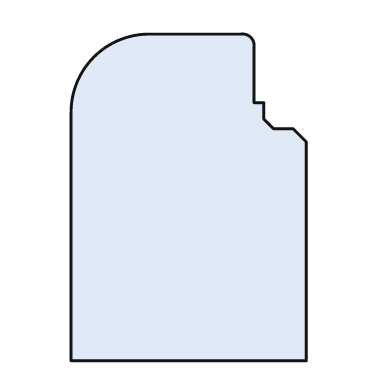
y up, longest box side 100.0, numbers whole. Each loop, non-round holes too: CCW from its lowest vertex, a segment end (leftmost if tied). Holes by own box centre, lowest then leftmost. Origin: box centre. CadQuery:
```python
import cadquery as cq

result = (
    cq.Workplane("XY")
    .moveTo(-36.0, -50.0)
    .lineTo(36.0, -50.0)
    .lineTo(36.0, 17.0)
    .lineTo(32.0, 21.0)
    .lineTo(26.0, 21.0)
    .lineTo(23.0, 24.0)
    .lineTo(23.0, 29.0)
    .lineTo(20.0, 29.0)
    .lineTo(20.0, 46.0)
    .threePointArc((19.0, 49.0), (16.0, 50.0))
    .lineTo(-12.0, 50.0)
    .threePointArc((-29.0, 43.0), (-36.0, 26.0))
    .close()
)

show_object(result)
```